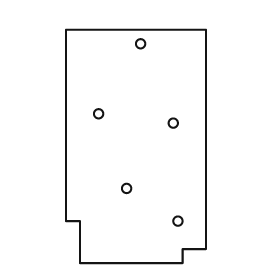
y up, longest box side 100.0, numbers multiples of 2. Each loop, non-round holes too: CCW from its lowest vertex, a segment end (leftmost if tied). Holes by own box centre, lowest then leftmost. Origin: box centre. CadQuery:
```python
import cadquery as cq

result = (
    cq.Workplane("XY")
    .moveTo(-24.0, -50.0)
    .lineTo(20.0, -50.0)
    .lineTo(20.0, -44.0)
    .lineTo(30.0, -44.0)
    .lineTo(30.0, 50.0)
    .lineTo(-30.0, 50.0)
    .lineTo(-30.0, -32.0)
    .lineTo(-24.0, -32.0)
    .close()
    .moveTo(18.0, -32.0)
    .circle(2.0)
    .moveTo(-4.0, -18.0)
    .circle(2.0)
    .moveTo(16.0, 10.0)
    .circle(2.0)
    .moveTo(-16.0, 14.0)
    .circle(2.0)
    .moveTo(2.0, 44.0)
    .circle(2.0)
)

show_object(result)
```